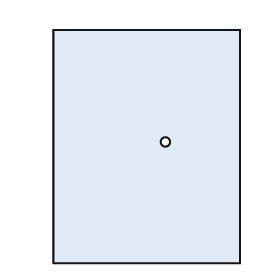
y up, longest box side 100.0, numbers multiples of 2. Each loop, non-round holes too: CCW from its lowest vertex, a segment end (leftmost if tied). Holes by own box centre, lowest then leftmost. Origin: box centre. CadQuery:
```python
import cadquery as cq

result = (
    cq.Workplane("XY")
    .moveTo(-40.0, -50.0)
    .lineTo(40.0, -50.0)
    .lineTo(40.0, 50.0)
    .lineTo(-40.0, 50.0)
    .close()
    .moveTo(8.0, 2.0)
    .circle(2.0)
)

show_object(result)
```